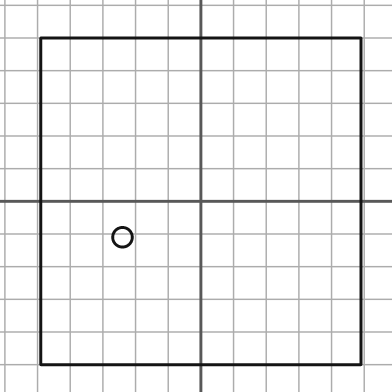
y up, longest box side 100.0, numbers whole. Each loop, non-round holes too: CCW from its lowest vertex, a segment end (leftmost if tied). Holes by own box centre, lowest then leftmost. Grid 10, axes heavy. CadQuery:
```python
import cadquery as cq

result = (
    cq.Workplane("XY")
    .moveTo(-49.0, -50.0)
    .lineTo(49.0, -50.0)
    .lineTo(49.0, 50.0)
    .lineTo(-49.0, 50.0)
    .close()
    .moveTo(-24.0, -11.0)
    .circle(3.0)
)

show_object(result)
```